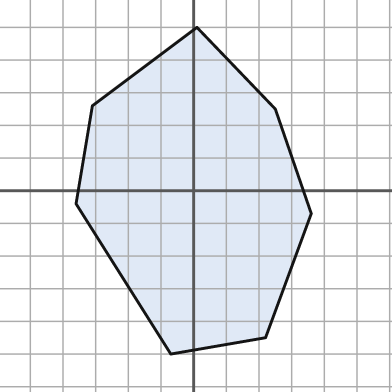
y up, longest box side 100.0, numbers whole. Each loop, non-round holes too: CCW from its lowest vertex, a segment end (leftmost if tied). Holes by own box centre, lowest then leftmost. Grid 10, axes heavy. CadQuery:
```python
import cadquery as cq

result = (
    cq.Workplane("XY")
    .moveTo(-7.0, -50.0)
    .lineTo(22.0, -45.0)
    .lineTo(36.0, -7.0)
    .lineTo(25.0, 25.0)
    .lineTo(1.0, 50.0)
    .lineTo(-31.0, 26.0)
    .lineTo(-36.0, -4.0)
    .close()
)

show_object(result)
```